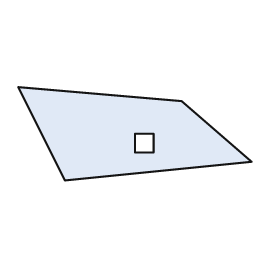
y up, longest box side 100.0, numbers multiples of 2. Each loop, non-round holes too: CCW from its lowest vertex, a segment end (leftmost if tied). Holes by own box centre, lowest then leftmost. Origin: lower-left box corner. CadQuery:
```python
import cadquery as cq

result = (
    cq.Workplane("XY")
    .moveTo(20.0, 0.0)
    .lineTo(100.0, 8.0)
    .lineTo(70.0, 34.0)
    .lineTo(0.0, 40.0)
    .close()
    .moveTo(50.0, 12.0)
    .lineTo(58.0, 12.0)
    .lineTo(58.0, 20.0)
    .lineTo(50.0, 20.0)
    .close()
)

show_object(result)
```